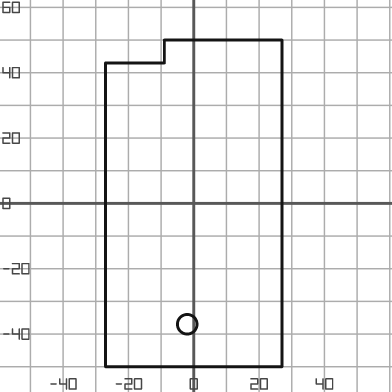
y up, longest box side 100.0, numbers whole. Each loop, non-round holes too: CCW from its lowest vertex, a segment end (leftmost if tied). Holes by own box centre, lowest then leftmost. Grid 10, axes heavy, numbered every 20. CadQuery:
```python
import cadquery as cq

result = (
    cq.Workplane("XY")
    .moveTo(-27.0, -50.0)
    .lineTo(27.0, -50.0)
    .lineTo(27.0, 50.0)
    .lineTo(-9.0, 50.0)
    .lineTo(-9.0, 43.0)
    .lineTo(-27.0, 43.0)
    .close()
    .moveTo(-2.0, -37.0)
    .circle(3.0)
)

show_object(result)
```